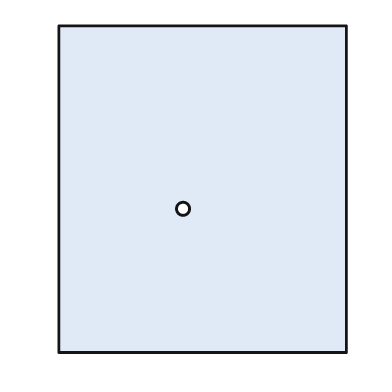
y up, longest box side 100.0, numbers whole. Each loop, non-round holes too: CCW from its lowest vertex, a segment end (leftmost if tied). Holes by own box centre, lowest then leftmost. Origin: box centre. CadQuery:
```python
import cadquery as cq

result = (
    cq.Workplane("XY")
    .moveTo(-44.0, -50.0)
    .lineTo(44.0, -50.0)
    .lineTo(44.0, 50.0)
    .lineTo(-44.0, 50.0)
    .close()
    .moveTo(-6.0, -6.0)
    .circle(2.0)
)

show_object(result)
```